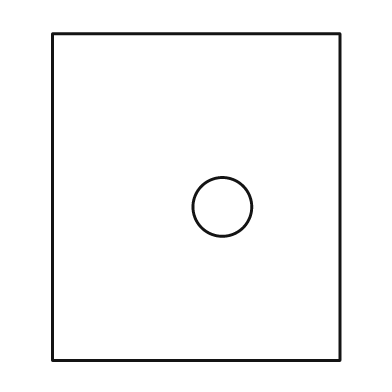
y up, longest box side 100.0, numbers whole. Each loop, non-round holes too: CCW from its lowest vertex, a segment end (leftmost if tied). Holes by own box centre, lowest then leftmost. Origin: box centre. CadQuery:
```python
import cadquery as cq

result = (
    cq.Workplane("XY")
    .moveTo(-44.0, -50.0)
    .lineTo(44.0, -50.0)
    .lineTo(44.0, 50.0)
    .lineTo(-44.0, 50.0)
    .close()
    .moveTo(8.0, -3.0)
    .circle(9.0)
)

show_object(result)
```